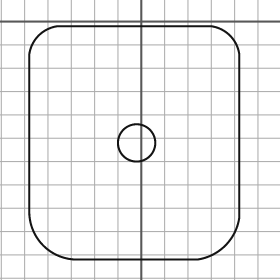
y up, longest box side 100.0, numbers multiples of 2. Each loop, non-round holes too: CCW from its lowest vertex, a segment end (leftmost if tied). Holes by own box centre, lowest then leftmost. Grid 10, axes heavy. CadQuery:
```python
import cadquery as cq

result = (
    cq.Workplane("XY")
    .moveTo(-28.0, -102.0)
    .lineTo(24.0, -102.0)
    .threePointArc((36.0, -96.0), (42.0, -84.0))
    .lineTo(42.0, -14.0)
    .threePointArc((38.0, -6.0), (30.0, -2.0))
    .lineTo(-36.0, -2.0)
    .threePointArc((-44.0, -6.0), (-48.0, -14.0))
    .lineTo(-48.0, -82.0)
    .threePointArc((-42.0, -96.0), (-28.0, -102.0))
    .close()
    .moveTo(-2.0, -52.0)
    .circle(8.0)
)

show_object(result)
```